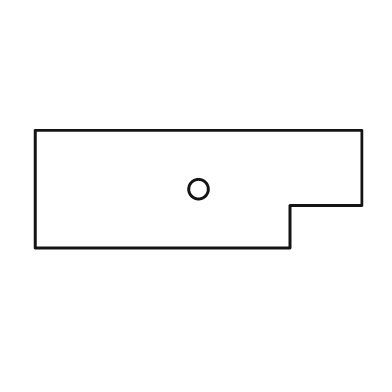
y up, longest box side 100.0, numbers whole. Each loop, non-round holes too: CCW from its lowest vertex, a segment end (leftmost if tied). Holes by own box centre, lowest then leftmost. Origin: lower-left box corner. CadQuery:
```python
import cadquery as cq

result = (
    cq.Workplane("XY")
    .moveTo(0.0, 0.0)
    .lineTo(78.0, 0.0)
    .lineTo(78.0, 13.0)
    .lineTo(100.0, 13.0)
    .lineTo(100.0, 36.0)
    .lineTo(0.0, 36.0)
    .close()
    .moveTo(50.0, 18.0)
    .circle(3.0)
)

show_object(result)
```